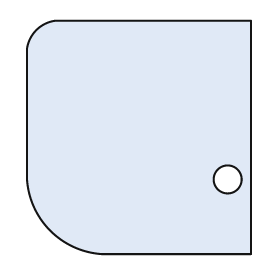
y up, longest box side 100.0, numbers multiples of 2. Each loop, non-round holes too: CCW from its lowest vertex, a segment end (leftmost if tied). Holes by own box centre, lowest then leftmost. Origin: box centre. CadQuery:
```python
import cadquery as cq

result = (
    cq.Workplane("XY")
    .moveTo(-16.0, -50.0)
    .lineTo(48.0, -50.0)
    .lineTo(48.0, 50.0)
    .lineTo(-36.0, 50.0)
    .threePointArc((-44.0, 46.0), (-48.0, 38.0))
    .lineTo(-48.0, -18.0)
    .threePointArc((-38.0, -40.0), (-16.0, -50.0))
    .close()
    .moveTo(38.0, -18.0)
    .circle(6.0)
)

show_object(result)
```